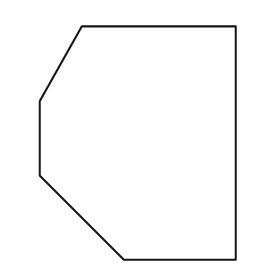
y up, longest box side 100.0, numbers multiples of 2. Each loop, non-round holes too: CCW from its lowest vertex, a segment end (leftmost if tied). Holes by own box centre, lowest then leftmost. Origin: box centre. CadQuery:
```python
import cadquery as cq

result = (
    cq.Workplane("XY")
    .moveTo(-6.0, -50.0)
    .lineTo(42.0, -50.0)
    .lineTo(42.0, 50.0)
    .lineTo(-24.0, 50.0)
    .lineTo(-42.0, 18.0)
    .lineTo(-42.0, -14.0)
    .close()
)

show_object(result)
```